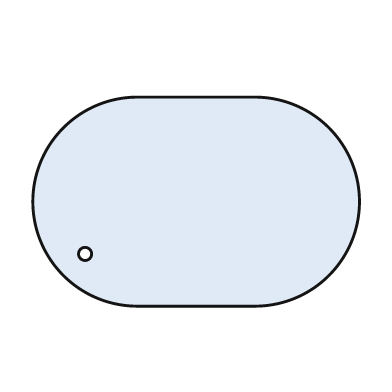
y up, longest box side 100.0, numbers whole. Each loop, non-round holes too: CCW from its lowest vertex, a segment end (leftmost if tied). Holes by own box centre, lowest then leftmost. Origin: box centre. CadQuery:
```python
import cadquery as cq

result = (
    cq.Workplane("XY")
    .moveTo(-18.0, -32.0)
    .lineTo(18.0, -32.0)
    .threePointArc((50.0, 0.0), (18.0, 32.0))
    .lineTo(-18.0, 32.0)
    .threePointArc((-50.0, 0.0), (-18.0, -32.0))
    .close()
    .moveTo(-34.0, -16.0)
    .circle(2.0)
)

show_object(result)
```